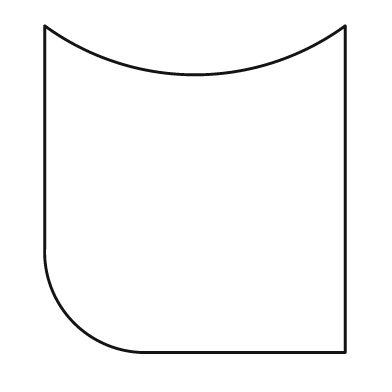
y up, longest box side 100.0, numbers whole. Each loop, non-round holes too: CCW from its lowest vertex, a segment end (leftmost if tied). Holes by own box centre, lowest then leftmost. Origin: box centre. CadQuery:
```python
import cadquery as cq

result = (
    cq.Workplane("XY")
    .moveTo(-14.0, -50.0)
    .lineTo(46.0, -50.0)
    .lineTo(46.0, 50.0)
    .threePointArc((0.0, 35.0), (-46.0, 50.0))
    .lineTo(-46.0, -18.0)
    .threePointArc((-37.0, -41.0), (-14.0, -50.0))
    .close()
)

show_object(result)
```